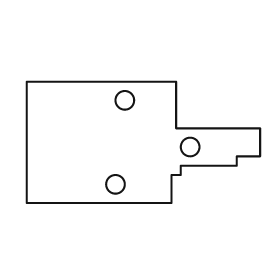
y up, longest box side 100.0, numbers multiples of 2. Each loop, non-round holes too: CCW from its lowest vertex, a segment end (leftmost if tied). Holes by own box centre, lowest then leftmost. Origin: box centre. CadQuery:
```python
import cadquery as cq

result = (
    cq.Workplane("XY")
    .moveTo(-50.0, -26.0)
    .lineTo(12.0, -26.0)
    .lineTo(12.0, -14.0)
    .lineTo(16.0, -14.0)
    .lineTo(16.0, -10.0)
    .lineTo(40.0, -10.0)
    .lineTo(40.0, -6.0)
    .lineTo(50.0, -6.0)
    .lineTo(50.0, 6.0)
    .lineTo(14.0, 6.0)
    .lineTo(14.0, 26.0)
    .lineTo(-50.0, 26.0)
    .close()
    .moveTo(-12.0, -18.0)
    .circle(4.0)
    .moveTo(20.0, -2.0)
    .circle(4.0)
    .moveTo(-8.0, 18.0)
    .circle(4.0)
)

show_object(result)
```